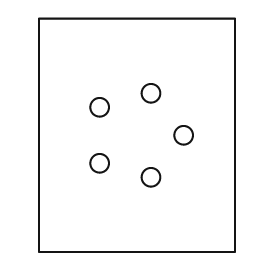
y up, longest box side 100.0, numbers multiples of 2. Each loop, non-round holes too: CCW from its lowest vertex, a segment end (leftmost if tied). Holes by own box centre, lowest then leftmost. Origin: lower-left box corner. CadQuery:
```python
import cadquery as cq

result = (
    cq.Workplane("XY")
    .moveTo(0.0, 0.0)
    .lineTo(84.0, 0.0)
    .lineTo(84.0, 100.0)
    .lineTo(0.0, 100.0)
    .close()
    .moveTo(48.0, 32.0)
    .circle(4.0)
    .moveTo(26.0, 38.0)
    .circle(4.0)
    .moveTo(62.0, 50.0)
    .circle(4.0)
    .moveTo(26.0, 62.0)
    .circle(4.0)
    .moveTo(48.0, 68.0)
    .circle(4.0)
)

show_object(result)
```